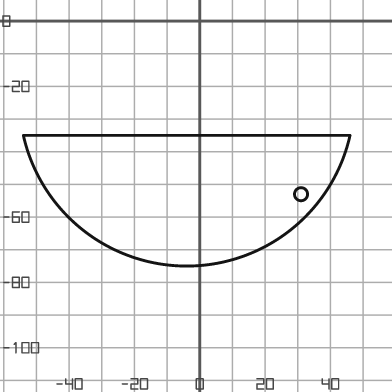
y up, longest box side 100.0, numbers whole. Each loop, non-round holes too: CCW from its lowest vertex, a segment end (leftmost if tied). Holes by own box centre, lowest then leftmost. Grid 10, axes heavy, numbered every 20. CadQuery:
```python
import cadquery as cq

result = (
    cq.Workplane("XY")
    .moveTo(-54.0, -35.0)
    .threePointArc((-4.0, -75.0), (46.0, -35.0))
    .close()
    .moveTo(31.0, -53.0)
    .circle(2.0)
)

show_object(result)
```